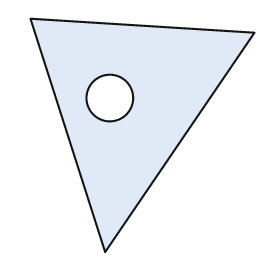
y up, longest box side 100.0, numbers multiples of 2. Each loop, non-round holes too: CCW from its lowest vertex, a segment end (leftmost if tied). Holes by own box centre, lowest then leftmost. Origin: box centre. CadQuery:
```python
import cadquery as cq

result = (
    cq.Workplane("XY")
    .moveTo(-16.0, -50.0)
    .lineTo(48.0, 44.0)
    .lineTo(-48.0, 50.0)
    .close()
    .moveTo(-14.0, 16.0)
    .circle(10.0)
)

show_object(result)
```